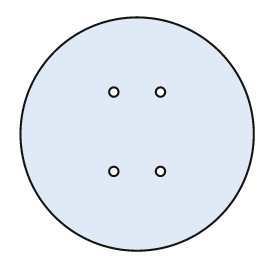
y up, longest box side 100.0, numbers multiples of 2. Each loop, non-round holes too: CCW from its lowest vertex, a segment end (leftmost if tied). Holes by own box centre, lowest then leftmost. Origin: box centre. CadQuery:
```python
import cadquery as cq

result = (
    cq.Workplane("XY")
    .moveTo(0.0, 0.0)
    .circle(50.0)
    .moveTo(-10.0, -16.0)
    .circle(2.0)
    .moveTo(10.0, -16.0)
    .circle(2.0)
    .moveTo(-10.0, 18.0)
    .circle(2.0)
    .moveTo(10.0, 18.0)
    .circle(2.0)
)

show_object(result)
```